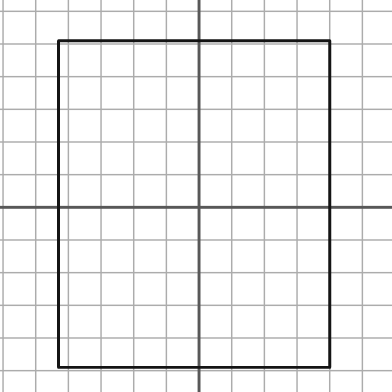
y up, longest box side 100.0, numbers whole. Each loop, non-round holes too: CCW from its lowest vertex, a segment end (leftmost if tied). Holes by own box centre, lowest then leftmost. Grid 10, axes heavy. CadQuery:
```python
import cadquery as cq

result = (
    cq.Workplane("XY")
    .moveTo(-43.0, -49.0)
    .lineTo(40.0, -49.0)
    .lineTo(40.0, 51.0)
    .lineTo(-43.0, 51.0)
    .close()
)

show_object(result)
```